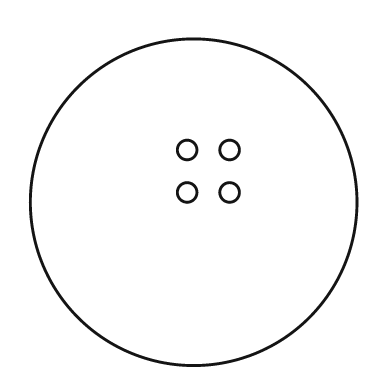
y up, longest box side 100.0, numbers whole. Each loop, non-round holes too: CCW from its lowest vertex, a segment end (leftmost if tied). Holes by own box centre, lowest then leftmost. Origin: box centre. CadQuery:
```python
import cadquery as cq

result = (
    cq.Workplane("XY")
    .moveTo(0.0, 0.0)
    .circle(50.0)
    .moveTo(-2.0, 3.0)
    .circle(3.0)
    .moveTo(11.0, 3.0)
    .circle(3.0)
    .moveTo(-2.0, 16.0)
    .circle(3.0)
    .moveTo(11.0, 16.0)
    .circle(3.0)
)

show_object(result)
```